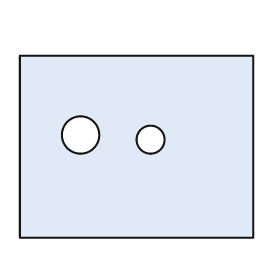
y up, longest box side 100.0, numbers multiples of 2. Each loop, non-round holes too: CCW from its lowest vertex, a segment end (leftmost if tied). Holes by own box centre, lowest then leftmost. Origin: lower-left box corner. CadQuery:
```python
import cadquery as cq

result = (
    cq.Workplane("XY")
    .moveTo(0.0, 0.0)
    .lineTo(100.0, 0.0)
    .lineTo(100.0, 78.0)
    .lineTo(0.0, 78.0)
    .close()
    .moveTo(56.0, 42.0)
    .circle(6.0)
    .moveTo(26.0, 44.0)
    .circle(8.0)
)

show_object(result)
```